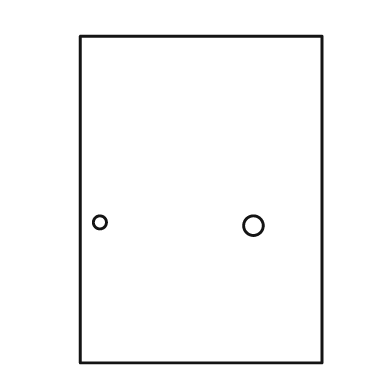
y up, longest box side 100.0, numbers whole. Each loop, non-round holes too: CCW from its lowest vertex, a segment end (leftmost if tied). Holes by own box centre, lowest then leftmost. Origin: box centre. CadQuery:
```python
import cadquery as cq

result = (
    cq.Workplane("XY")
    .moveTo(-37.0, -50.0)
    .lineTo(37.0, -50.0)
    .lineTo(37.0, 50.0)
    .lineTo(-37.0, 50.0)
    .close()
    .moveTo(16.0, -8.0)
    .circle(3.0)
    .moveTo(-31.0, -7.0)
    .circle(2.0)
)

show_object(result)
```